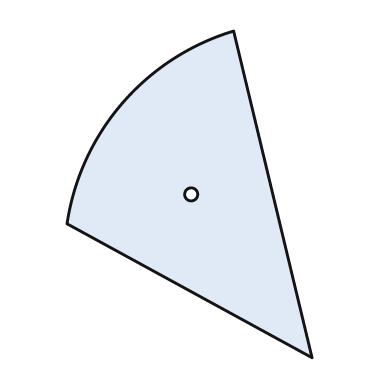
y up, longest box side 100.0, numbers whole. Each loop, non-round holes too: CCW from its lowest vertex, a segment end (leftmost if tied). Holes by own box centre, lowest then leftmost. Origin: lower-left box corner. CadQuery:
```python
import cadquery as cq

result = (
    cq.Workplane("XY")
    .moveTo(75.0, 0.0)
    .lineTo(51.0, 100.0)
    .threePointArc((17.0, 78.0), (0.0, 41.0))
    .close()
    .moveTo(38.0, 50.0)
    .circle(2.0)
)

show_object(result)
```